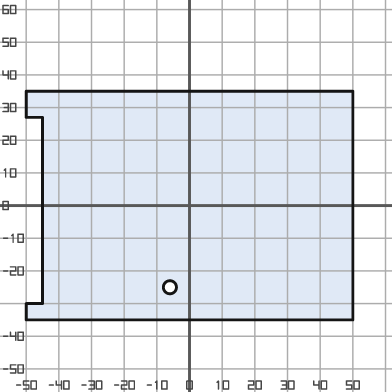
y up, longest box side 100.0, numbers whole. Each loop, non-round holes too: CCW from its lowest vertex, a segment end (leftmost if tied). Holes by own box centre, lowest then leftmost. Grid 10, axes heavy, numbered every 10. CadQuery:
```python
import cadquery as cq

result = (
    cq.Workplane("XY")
    .moveTo(-50.0, -35.0)
    .lineTo(50.0, -35.0)
    .lineTo(50.0, 35.0)
    .lineTo(-50.0, 35.0)
    .lineTo(-50.0, 27.0)
    .lineTo(-45.0, 27.0)
    .lineTo(-45.0, -30.0)
    .lineTo(-50.0, -30.0)
    .close()
    .moveTo(-6.0, -25.0)
    .circle(2.0)
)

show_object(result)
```